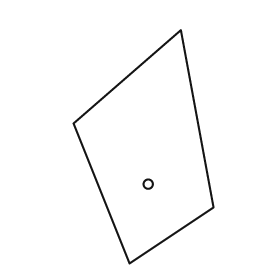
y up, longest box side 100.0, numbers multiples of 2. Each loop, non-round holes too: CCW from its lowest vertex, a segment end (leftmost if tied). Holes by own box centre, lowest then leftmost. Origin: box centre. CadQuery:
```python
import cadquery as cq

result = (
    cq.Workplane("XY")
    .moveTo(-6.0, -50.0)
    .lineTo(30.0, -26.0)
    .lineTo(16.0, 50.0)
    .lineTo(-30.0, 10.0)
    .close()
    .moveTo(2.0, -16.0)
    .circle(2.0)
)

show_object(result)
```